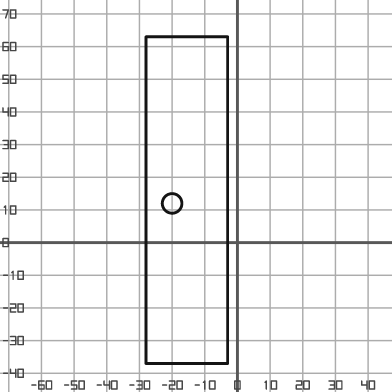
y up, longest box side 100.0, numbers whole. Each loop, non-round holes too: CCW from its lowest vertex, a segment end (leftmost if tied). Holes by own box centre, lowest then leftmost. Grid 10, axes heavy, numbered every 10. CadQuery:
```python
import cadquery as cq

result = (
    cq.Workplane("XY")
    .moveTo(-28.0, -37.0)
    .lineTo(-3.0, -37.0)
    .lineTo(-3.0, 63.0)
    .lineTo(-28.0, 63.0)
    .close()
    .moveTo(-20.0, 12.0)
    .circle(3.0)
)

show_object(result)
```